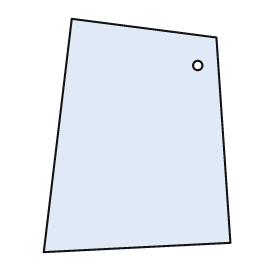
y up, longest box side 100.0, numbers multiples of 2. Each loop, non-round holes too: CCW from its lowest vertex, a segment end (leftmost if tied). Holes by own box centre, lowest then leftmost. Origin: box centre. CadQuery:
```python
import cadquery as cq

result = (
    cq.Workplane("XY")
    .moveTo(-40.0, -50.0)
    .lineTo(40.0, -46.0)
    .lineTo(34.0, 42.0)
    .lineTo(-28.0, 50.0)
    .close()
    .moveTo(26.0, 30.0)
    .circle(2.0)
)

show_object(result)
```